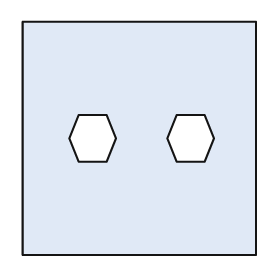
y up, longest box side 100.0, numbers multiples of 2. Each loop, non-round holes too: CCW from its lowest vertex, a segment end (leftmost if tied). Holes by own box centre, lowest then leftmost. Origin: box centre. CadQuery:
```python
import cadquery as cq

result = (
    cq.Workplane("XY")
    .moveTo(-50.0, -50.0)
    .lineTo(50.0, -50.0)
    .lineTo(50.0, 50.0)
    .lineTo(-50.0, 50.0)
    .close()
    .moveTo(-26.0, -10.0)
    .lineTo(-14.0, -10.0)
    .lineTo(-10.0, 0.0)
    .lineTo(-14.0, 10.0)
    .lineTo(-26.0, 10.0)
    .lineTo(-30.0, 0.0)
    .close()
    .moveTo(16.0, -10.0)
    .lineTo(28.0, -10.0)
    .lineTo(32.0, 0.0)
    .lineTo(28.0, 10.0)
    .lineTo(16.0, 10.0)
    .lineTo(12.0, 0.0)
    .close()
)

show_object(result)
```